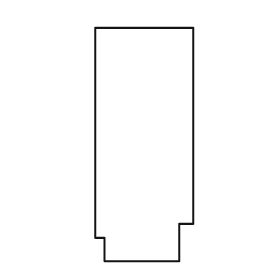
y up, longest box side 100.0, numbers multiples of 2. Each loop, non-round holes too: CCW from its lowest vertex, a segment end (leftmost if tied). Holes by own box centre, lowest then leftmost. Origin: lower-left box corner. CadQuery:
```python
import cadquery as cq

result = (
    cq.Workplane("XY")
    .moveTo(4.0, 0.0)
    .lineTo(36.0, 0.0)
    .lineTo(36.0, 16.0)
    .lineTo(42.0, 16.0)
    .lineTo(42.0, 100.0)
    .lineTo(0.0, 100.0)
    .lineTo(0.0, 10.0)
    .lineTo(4.0, 10.0)
    .close()
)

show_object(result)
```